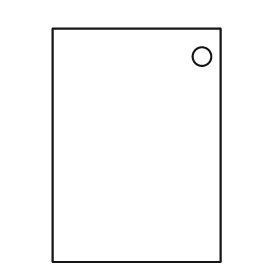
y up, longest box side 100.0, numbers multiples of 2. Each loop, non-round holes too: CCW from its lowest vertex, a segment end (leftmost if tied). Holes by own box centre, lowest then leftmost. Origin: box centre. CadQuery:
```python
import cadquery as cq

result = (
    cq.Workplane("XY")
    .moveTo(-36.0, -50.0)
    .lineTo(36.0, -50.0)
    .lineTo(36.0, 50.0)
    .lineTo(-36.0, 50.0)
    .close()
    .moveTo(28.0, 38.0)
    .circle(4.0)
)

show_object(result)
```